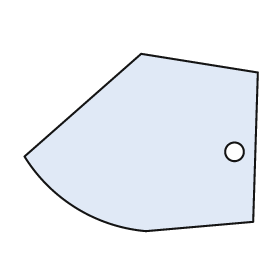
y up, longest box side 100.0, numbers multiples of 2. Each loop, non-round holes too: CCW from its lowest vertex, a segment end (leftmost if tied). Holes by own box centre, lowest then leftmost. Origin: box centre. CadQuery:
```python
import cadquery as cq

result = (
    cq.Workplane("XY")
    .moveTo(2.0, -38.0)
    .lineTo(48.0, -34.0)
    .lineTo(50.0, 30.0)
    .lineTo(0.0, 38.0)
    .lineTo(-50.0, -6.0)
    .threePointArc((-28.0, -28.0), (2.0, -38.0))
    .close()
    .moveTo(40.0, -4.0)
    .circle(4.0)
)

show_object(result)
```